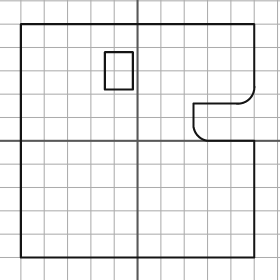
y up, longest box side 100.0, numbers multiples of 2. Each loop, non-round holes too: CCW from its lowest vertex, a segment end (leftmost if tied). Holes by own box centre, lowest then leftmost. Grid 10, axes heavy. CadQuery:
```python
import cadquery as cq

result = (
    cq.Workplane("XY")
    .moveTo(-50.0, -50.0)
    .lineTo(50.0, -50.0)
    .lineTo(50.0, 0.0)
    .lineTo(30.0, 0.0)
    .threePointArc((26.0, 2.0), (24.0, 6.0))
    .lineTo(24.0, 16.0)
    .lineTo(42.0, 16.0)
    .threePointArc((48.0, 18.0), (50.0, 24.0))
    .lineTo(50.0, 50.0)
    .lineTo(-50.0, 50.0)
    .close()
    .moveTo(-14.0, 22.0)
    .lineTo(-2.0, 22.0)
    .lineTo(-2.0, 38.0)
    .lineTo(-14.0, 38.0)
    .close()
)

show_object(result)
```